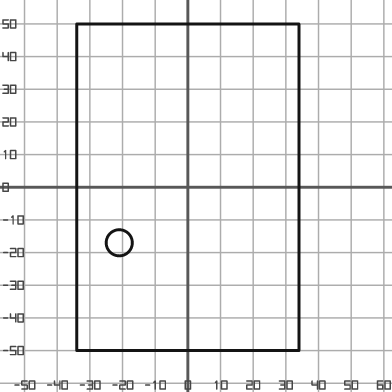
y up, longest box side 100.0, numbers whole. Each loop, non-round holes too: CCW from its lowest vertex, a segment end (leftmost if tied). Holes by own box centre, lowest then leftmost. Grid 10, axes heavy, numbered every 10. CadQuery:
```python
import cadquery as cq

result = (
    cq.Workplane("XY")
    .moveTo(-34.0, -50.0)
    .lineTo(34.0, -50.0)
    .lineTo(34.0, 50.0)
    .lineTo(-34.0, 50.0)
    .close()
    .moveTo(-21.0, -17.0)
    .circle(4.0)
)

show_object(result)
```